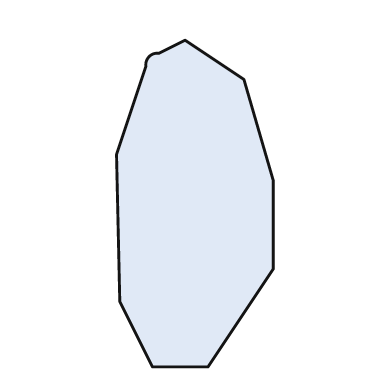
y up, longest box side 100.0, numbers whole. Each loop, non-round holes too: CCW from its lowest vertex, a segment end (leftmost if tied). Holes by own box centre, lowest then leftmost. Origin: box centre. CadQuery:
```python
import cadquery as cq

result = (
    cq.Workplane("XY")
    .moveTo(-13.0, -50.0)
    .lineTo(4.0, -50.0)
    .lineTo(24.0, -20.0)
    .lineTo(24.0, 7.0)
    .lineTo(15.0, 38.0)
    .lineTo(-3.0, 50.0)
    .lineTo(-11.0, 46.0)
    .threePointArc((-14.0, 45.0), (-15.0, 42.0))
    .lineTo(-24.0, 15.0)
    .lineTo(-23.0, -30.0)
    .close()
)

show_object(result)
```